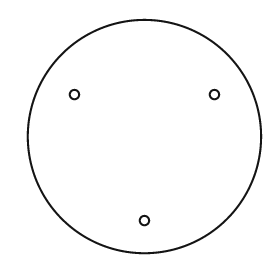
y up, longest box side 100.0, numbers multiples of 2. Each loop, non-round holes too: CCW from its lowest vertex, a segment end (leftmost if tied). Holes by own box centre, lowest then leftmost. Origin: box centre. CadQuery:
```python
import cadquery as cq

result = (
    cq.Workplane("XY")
    .moveTo(0.0, 0.0)
    .circle(50.0)
    .moveTo(0.0, -36.0)
    .circle(2.0)
    .moveTo(-30.0, 18.0)
    .circle(2.0)
    .moveTo(30.0, 18.0)
    .circle(2.0)
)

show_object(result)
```